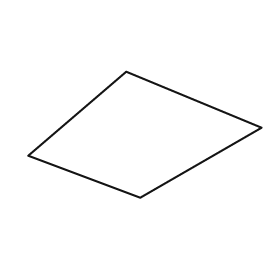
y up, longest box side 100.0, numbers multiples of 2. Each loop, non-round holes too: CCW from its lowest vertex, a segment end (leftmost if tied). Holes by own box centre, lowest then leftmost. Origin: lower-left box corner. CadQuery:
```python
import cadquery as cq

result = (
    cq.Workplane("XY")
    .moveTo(48.0, 0.0)
    .lineTo(100.0, 30.0)
    .lineTo(42.0, 54.0)
    .lineTo(0.0, 18.0)
    .close()
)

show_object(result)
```